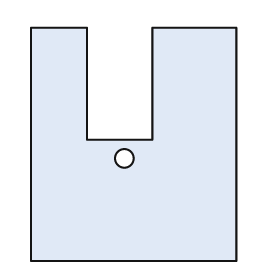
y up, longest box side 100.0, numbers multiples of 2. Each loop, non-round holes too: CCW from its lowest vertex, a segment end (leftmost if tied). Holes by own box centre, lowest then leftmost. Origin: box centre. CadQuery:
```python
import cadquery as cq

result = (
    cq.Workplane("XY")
    .moveTo(-44.0, -50.0)
    .lineTo(44.0, -50.0)
    .lineTo(44.0, 50.0)
    .lineTo(8.0, 50.0)
    .lineTo(8.0, 2.0)
    .lineTo(-20.0, 2.0)
    .lineTo(-20.0, 50.0)
    .lineTo(-44.0, 50.0)
    .close()
    .moveTo(-4.0, -6.0)
    .circle(4.0)
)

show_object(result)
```